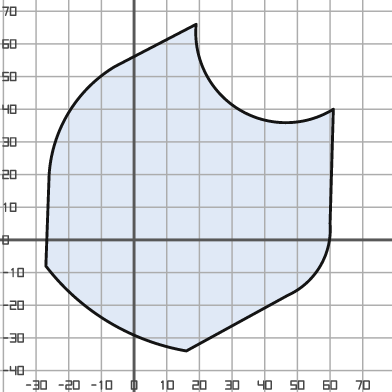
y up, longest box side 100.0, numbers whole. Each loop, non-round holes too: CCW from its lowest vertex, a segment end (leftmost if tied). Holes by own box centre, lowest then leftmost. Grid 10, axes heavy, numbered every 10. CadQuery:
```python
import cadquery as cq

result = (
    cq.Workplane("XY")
    .moveTo(16.0, -34.0)
    .lineTo(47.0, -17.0)
    .threePointArc((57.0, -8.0), (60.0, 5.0))
    .lineTo(61.0, 40.0)
    .threePointArc((32.0, 40.0), (19.0, 66.0))
    .lineTo(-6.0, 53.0)
    .threePointArc((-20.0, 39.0), (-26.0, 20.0))
    .lineTo(-27.0, -8.0)
    .threePointArc((-8.0, -25.0), (16.0, -34.0))
    .close()
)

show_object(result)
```